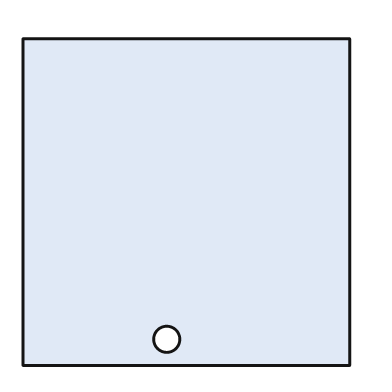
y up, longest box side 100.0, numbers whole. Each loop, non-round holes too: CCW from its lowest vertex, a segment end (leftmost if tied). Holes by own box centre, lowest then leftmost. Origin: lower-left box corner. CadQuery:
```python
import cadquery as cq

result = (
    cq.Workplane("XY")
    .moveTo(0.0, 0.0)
    .lineTo(100.0, 0.0)
    .lineTo(100.0, 100.0)
    .lineTo(0.0, 100.0)
    .close()
    .moveTo(44.0, 8.0)
    .circle(4.0)
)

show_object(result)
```